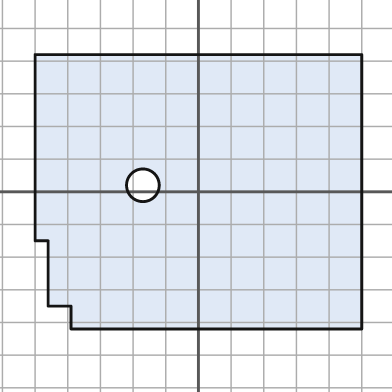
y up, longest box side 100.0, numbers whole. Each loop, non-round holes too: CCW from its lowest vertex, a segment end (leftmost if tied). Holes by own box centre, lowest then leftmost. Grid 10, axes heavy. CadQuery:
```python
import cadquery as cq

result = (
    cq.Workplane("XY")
    .moveTo(-39.0, -42.0)
    .lineTo(50.0, -42.0)
    .lineTo(50.0, 42.0)
    .lineTo(-50.0, 42.0)
    .lineTo(-50.0, -15.0)
    .lineTo(-46.0, -15.0)
    .lineTo(-46.0, -35.0)
    .lineTo(-39.0, -35.0)
    .close()
    .moveTo(-17.0, 2.0)
    .circle(5.0)
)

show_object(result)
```